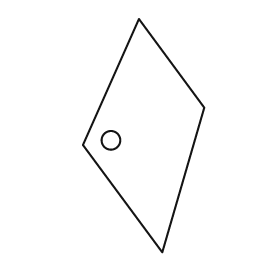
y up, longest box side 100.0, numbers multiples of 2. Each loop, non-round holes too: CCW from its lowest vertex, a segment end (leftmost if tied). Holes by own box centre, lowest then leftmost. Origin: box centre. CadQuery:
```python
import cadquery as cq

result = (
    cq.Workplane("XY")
    .moveTo(8.0, -50.0)
    .lineTo(26.0, 12.0)
    .lineTo(-2.0, 50.0)
    .lineTo(-26.0, -4.0)
    .close()
    .moveTo(-14.0, -2.0)
    .circle(4.0)
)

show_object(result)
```